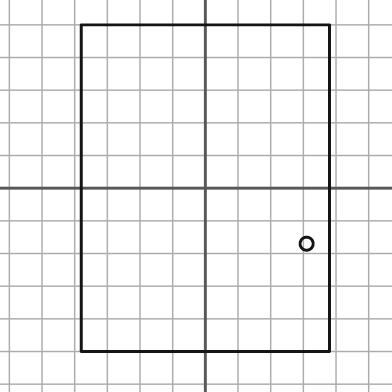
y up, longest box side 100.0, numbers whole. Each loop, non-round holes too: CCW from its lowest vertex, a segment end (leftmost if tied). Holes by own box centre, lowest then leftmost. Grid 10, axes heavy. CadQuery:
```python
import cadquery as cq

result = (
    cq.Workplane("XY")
    .moveTo(-38.0, -50.0)
    .lineTo(38.0, -50.0)
    .lineTo(38.0, 50.0)
    .lineTo(-38.0, 50.0)
    .close()
    .moveTo(31.0, -17.0)
    .circle(2.0)
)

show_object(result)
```